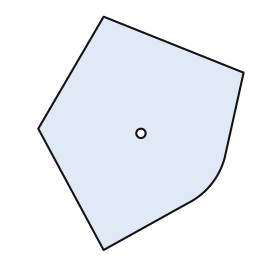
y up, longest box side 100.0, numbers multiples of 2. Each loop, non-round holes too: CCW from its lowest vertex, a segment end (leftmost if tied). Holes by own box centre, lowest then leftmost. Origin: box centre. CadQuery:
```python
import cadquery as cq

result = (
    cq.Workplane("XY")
    .moveTo(-16.0, -50.0)
    .lineTo(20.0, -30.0)
    .threePointArc((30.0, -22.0), (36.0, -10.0))
    .lineTo(44.0, 26.0)
    .lineTo(-16.0, 50.0)
    .lineTo(-44.0, 2.0)
    .close()
    .moveTo(0.0, 0.0)
    .circle(2.0)
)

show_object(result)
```